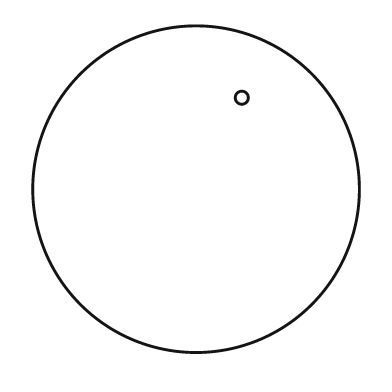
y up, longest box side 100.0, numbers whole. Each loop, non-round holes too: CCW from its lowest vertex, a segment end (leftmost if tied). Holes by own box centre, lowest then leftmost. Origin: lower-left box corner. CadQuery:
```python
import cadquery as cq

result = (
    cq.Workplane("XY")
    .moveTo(50.0, 50.0)
    .circle(50.0)
    .moveTo(64.0, 78.0)
    .circle(2.0)
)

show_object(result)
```